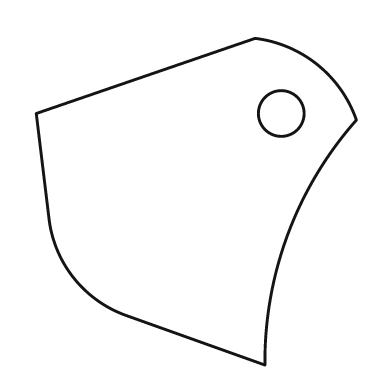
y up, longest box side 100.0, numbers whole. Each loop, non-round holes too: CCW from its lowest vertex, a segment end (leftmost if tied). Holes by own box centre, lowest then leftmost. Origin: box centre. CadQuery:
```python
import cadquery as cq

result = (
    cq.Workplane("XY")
    .moveTo(21.0, -50.0)
    .threePointArc((28.0, -10.0), (49.0, 25.0))
    .threePointArc((37.0, 42.0), (18.0, 50.0))
    .lineTo(-49.0, 27.0)
    .lineTo(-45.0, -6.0)
    .threePointArc((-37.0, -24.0), (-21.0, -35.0))
    .close()
    .moveTo(26.0, 27.0)
    .circle(7.0)
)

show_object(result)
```